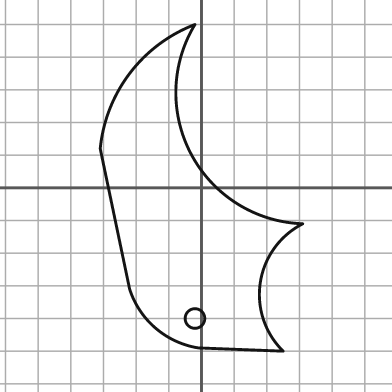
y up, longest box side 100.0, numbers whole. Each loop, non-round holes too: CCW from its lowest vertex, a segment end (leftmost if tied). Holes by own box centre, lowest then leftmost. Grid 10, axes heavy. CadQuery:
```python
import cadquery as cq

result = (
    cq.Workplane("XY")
    .moveTo(25.0, -50.0)
    .threePointArc((18.0, -29.0), (31.0, -11.0))
    .threePointArc((-3.0, 10.0), (-2.0, 50.0))
    .threePointArc((-22.0, 35.0), (-31.0, 12.0))
    .lineTo(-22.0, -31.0)
    .threePointArc((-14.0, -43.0), (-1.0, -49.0))
    .close()
    .moveTo(-2.0, -40.0)
    .circle(3.0)
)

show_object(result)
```